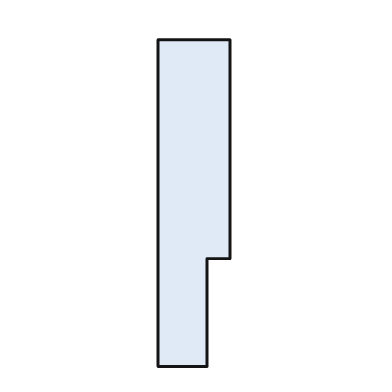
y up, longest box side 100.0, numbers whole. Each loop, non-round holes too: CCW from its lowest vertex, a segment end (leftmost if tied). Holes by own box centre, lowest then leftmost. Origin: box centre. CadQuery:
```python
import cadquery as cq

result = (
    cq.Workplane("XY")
    .moveTo(-11.0, -50.0)
    .lineTo(4.0, -50.0)
    .lineTo(4.0, -17.0)
    .lineTo(11.0, -17.0)
    .lineTo(11.0, 50.0)
    .lineTo(-11.0, 50.0)
    .close()
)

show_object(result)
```